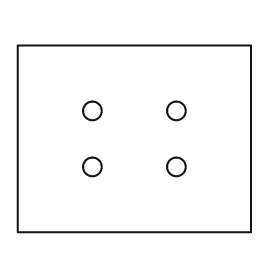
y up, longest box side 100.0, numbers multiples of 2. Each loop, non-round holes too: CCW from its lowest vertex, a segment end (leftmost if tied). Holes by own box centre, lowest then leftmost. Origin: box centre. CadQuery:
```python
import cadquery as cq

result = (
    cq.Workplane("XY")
    .moveTo(-50.0, -40.0)
    .lineTo(50.0, -40.0)
    .lineTo(50.0, 40.0)
    .lineTo(-50.0, 40.0)
    .close()
    .moveTo(-18.0, -12.0)
    .circle(4.0)
    .moveTo(18.0, -12.0)
    .circle(4.0)
    .moveTo(-18.0, 12.0)
    .circle(4.0)
    .moveTo(18.0, 12.0)
    .circle(4.0)
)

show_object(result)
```